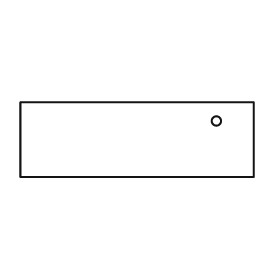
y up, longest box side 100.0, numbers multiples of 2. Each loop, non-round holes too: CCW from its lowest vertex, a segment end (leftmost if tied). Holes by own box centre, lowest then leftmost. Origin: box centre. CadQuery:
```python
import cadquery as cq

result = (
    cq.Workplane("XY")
    .moveTo(-50.0, -16.0)
    .lineTo(50.0, -16.0)
    .lineTo(50.0, 16.0)
    .lineTo(-50.0, 16.0)
    .close()
    .moveTo(34.0, 8.0)
    .circle(2.0)
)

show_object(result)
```